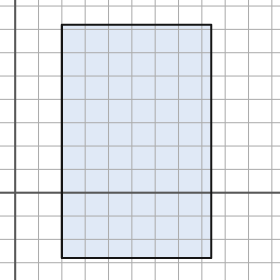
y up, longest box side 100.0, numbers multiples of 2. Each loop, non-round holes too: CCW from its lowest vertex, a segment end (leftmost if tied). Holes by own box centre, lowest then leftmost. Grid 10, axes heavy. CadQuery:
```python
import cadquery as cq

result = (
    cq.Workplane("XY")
    .moveTo(20.0, -28.0)
    .lineTo(84.0, -28.0)
    .lineTo(84.0, 72.0)
    .lineTo(20.0, 72.0)
    .close()
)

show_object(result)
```